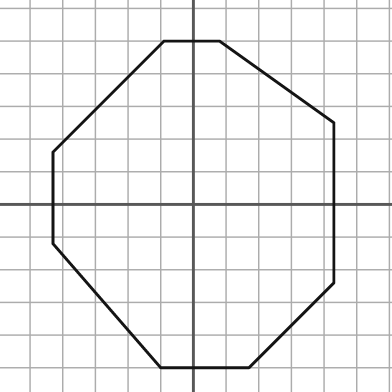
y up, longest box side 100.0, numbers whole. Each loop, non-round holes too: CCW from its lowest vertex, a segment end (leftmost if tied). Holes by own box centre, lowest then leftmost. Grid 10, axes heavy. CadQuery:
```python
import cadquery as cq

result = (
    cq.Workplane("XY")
    .moveTo(-10.0, -50.0)
    .lineTo(17.0, -50.0)
    .lineTo(43.0, -24.0)
    .lineTo(43.0, 25.0)
    .lineTo(8.0, 50.0)
    .lineTo(-9.0, 50.0)
    .lineTo(-43.0, 16.0)
    .lineTo(-43.0, -12.0)
    .close()
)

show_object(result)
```